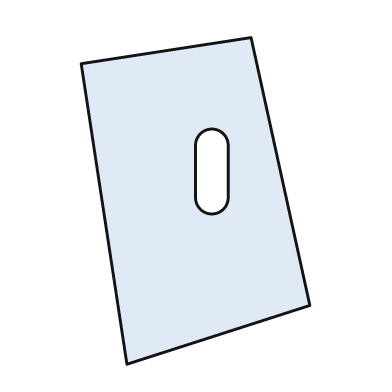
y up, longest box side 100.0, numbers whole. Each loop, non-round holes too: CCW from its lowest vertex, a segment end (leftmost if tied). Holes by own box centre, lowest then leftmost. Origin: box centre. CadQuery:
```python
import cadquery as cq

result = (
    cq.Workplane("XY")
    .moveTo(-21.0, -50.0)
    .lineTo(35.0, -32.0)
    .lineTo(17.0, 50.0)
    .lineTo(-35.0, 42.0)
    .close()
    .moveTo(0.0, 1.0)
    .threePointArc((5.0, -4.0), (10.0, 1.0))
    .lineTo(10.0, 17.0)
    .threePointArc((5.0, 22.0), (0.0, 17.0))
    .close()
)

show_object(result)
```